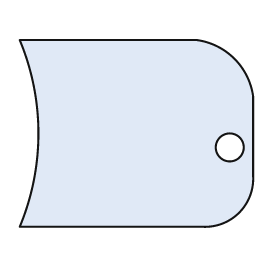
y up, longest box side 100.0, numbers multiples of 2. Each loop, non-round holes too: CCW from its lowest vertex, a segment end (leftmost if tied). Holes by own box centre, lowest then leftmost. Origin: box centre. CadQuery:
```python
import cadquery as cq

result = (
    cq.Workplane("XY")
    .moveTo(-50.0, -40.0)
    .lineTo(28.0, -40.0)
    .threePointArc((44.0, -34.0), (50.0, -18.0))
    .lineTo(50.0, 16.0)
    .threePointArc((42.0, 32.0), (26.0, 40.0))
    .lineTo(-50.0, 40.0)
    .threePointArc((-42.0, 0.0), (-50.0, -40.0))
    .close()
    .moveTo(40.0, -6.0)
    .circle(6.0)
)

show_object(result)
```